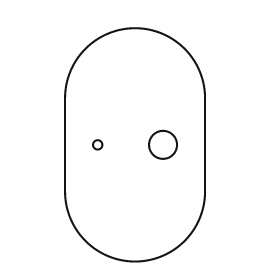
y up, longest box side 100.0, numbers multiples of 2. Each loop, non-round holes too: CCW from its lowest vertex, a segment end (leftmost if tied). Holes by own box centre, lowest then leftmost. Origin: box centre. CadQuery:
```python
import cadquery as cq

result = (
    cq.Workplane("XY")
    .moveTo(-30.0, -20.0)
    .threePointArc((0.0, -50.0), (30.0, -20.0))
    .lineTo(30.0, 20.0)
    .threePointArc((0.0, 50.0), (-30.0, 20.0))
    .close()
    .moveTo(-16.0, 0.0)
    .circle(2.0)
    .moveTo(12.0, 0.0)
    .circle(6.0)
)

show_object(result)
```